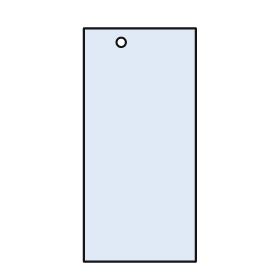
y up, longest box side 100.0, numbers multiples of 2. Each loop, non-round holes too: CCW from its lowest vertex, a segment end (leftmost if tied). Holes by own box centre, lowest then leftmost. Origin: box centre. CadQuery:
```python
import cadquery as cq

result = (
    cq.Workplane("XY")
    .moveTo(-24.0, -50.0)
    .lineTo(24.0, -50.0)
    .lineTo(24.0, 50.0)
    .lineTo(-24.0, 50.0)
    .close()
    .moveTo(-8.0, 44.0)
    .circle(2.0)
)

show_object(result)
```